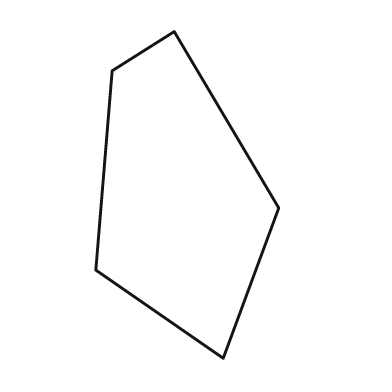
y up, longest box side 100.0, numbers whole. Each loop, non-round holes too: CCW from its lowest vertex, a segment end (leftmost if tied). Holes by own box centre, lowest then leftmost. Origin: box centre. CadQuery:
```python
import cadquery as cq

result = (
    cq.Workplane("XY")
    .moveTo(11.0, -50.0)
    .lineTo(28.0, -4.0)
    .lineTo(-4.0, 50.0)
    .lineTo(-23.0, 38.0)
    .lineTo(-28.0, -23.0)
    .close()
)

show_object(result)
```